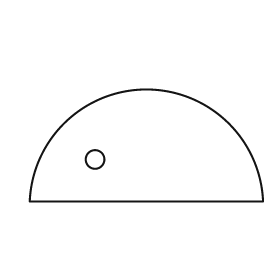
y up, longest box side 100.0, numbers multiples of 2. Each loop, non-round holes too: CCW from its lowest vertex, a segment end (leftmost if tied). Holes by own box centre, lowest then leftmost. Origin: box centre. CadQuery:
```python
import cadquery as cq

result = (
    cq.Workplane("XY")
    .moveTo(-50.0, -24.0)
    .lineTo(50.0, -24.0)
    .threePointArc((0.0, 24.0), (-50.0, -24.0))
    .close()
    .moveTo(-22.0, -6.0)
    .circle(4.0)
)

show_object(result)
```